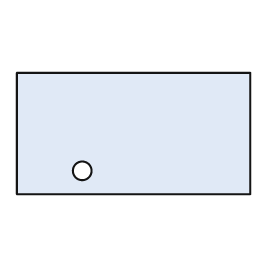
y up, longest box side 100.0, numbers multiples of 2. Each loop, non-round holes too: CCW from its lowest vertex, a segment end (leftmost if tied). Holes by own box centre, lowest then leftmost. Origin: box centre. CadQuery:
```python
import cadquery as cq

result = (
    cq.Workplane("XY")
    .moveTo(-50.0, -26.0)
    .lineTo(50.0, -26.0)
    .lineTo(50.0, 26.0)
    .lineTo(-50.0, 26.0)
    .close()
    .moveTo(-22.0, -16.0)
    .circle(4.0)
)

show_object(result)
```